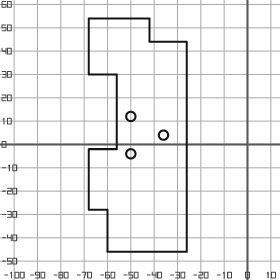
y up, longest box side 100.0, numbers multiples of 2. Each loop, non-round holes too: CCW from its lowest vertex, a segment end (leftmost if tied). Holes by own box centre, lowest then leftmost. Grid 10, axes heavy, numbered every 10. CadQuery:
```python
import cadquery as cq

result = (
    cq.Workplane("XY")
    .moveTo(-60.0, -46.0)
    .lineTo(-26.0, -46.0)
    .lineTo(-26.0, 44.0)
    .lineTo(-42.0, 44.0)
    .lineTo(-42.0, 54.0)
    .lineTo(-68.0, 54.0)
    .lineTo(-68.0, 30.0)
    .lineTo(-56.0, 30.0)
    .lineTo(-56.0, -2.0)
    .lineTo(-68.0, -2.0)
    .lineTo(-68.0, -28.0)
    .lineTo(-60.0, -28.0)
    .close()
    .moveTo(-50.0, -4.0)
    .circle(2.0)
    .moveTo(-36.0, 4.0)
    .circle(2.0)
    .moveTo(-50.0, 12.0)
    .circle(2.0)
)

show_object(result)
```